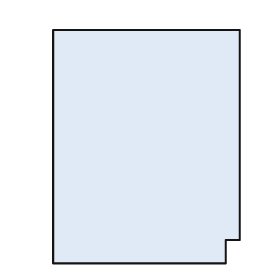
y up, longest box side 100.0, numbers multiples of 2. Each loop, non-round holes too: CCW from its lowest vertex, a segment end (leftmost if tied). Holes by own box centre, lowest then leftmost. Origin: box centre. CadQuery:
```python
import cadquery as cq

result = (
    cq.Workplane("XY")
    .moveTo(-40.0, -50.0)
    .lineTo(34.0, -50.0)
    .lineTo(34.0, -40.0)
    .lineTo(40.0, -40.0)
    .lineTo(40.0, 50.0)
    .lineTo(-40.0, 50.0)
    .close()
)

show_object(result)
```